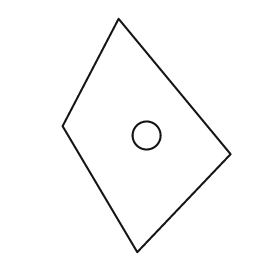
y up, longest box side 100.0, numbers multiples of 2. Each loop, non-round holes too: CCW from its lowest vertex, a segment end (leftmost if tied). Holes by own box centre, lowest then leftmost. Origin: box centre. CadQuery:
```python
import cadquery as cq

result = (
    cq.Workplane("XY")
    .moveTo(-4.0, -50.0)
    .lineTo(36.0, -8.0)
    .lineTo(-12.0, 50.0)
    .lineTo(-36.0, 4.0)
    .close()
    .moveTo(0.0, 0.0)
    .circle(6.0)
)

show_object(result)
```